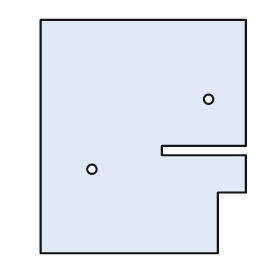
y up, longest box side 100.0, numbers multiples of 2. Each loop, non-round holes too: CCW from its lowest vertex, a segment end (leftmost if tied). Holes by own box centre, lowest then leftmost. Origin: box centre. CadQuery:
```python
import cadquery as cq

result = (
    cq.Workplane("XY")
    .moveTo(-44.0, -50.0)
    .lineTo(32.0, -50.0)
    .lineTo(32.0, -24.0)
    .lineTo(44.0, -24.0)
    .lineTo(44.0, -8.0)
    .lineTo(8.0, -8.0)
    .lineTo(8.0, -4.0)
    .lineTo(44.0, -4.0)
    .lineTo(44.0, 50.0)
    .lineTo(-44.0, 50.0)
    .close()
    .moveTo(-22.0, -14.0)
    .circle(2.0)
    .moveTo(28.0, 16.0)
    .circle(2.0)
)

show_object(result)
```